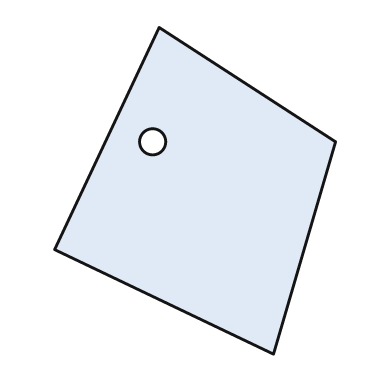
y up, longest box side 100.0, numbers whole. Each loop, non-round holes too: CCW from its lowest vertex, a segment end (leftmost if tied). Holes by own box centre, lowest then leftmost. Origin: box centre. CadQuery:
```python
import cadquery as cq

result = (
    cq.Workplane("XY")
    .moveTo(24.0, -50.0)
    .lineTo(43.0, 15.0)
    .lineTo(-11.0, 50.0)
    .lineTo(-43.0, -18.0)
    .close()
    .moveTo(-13.0, 15.0)
    .circle(4.0)
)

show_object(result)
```